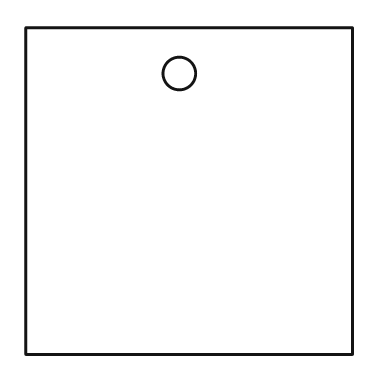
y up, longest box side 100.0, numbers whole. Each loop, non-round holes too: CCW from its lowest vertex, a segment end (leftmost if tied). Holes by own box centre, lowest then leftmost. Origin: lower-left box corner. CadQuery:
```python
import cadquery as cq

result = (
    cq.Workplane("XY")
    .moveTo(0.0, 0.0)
    .lineTo(100.0, 0.0)
    .lineTo(100.0, 100.0)
    .lineTo(0.0, 100.0)
    .close()
    .moveTo(47.0, 86.0)
    .circle(5.0)
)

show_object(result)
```